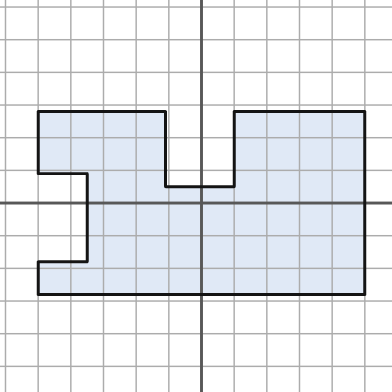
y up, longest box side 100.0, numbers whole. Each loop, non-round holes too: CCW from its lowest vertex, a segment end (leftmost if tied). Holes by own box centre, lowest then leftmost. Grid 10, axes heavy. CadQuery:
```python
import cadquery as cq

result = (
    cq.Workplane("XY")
    .moveTo(-50.0, -28.0)
    .lineTo(50.0, -28.0)
    .lineTo(50.0, 28.0)
    .lineTo(10.0, 28.0)
    .lineTo(10.0, 5.0)
    .lineTo(-11.0, 5.0)
    .lineTo(-11.0, 28.0)
    .lineTo(-50.0, 28.0)
    .lineTo(-50.0, 9.0)
    .lineTo(-35.0, 9.0)
    .lineTo(-35.0, -18.0)
    .lineTo(-50.0, -18.0)
    .close()
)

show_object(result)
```